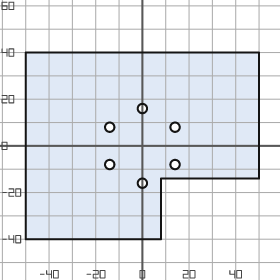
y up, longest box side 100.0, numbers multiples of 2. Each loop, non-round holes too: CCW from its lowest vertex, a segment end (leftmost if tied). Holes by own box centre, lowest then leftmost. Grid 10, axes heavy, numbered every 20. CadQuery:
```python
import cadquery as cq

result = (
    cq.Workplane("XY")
    .moveTo(-50.0, -40.0)
    .lineTo(8.0, -40.0)
    .lineTo(8.0, -14.0)
    .lineTo(50.0, -14.0)
    .lineTo(50.0, 40.0)
    .lineTo(-50.0, 40.0)
    .close()
    .moveTo(0.0, -16.0)
    .circle(2.0)
    .moveTo(-14.0, -8.0)
    .circle(2.0)
    .moveTo(14.0, -8.0)
    .circle(2.0)
    .moveTo(-14.0, 8.0)
    .circle(2.0)
    .moveTo(14.0, 8.0)
    .circle(2.0)
    .moveTo(0.0, 16.0)
    .circle(2.0)
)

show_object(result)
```